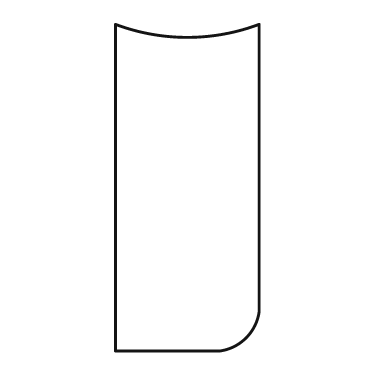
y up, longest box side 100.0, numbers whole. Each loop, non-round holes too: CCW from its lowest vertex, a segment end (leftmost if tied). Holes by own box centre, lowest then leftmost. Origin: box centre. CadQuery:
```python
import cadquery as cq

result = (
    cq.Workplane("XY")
    .moveTo(-22.0, -50.0)
    .lineTo(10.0, -50.0)
    .threePointArc((18.0, -46.0), (22.0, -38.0))
    .lineTo(22.0, 50.0)
    .threePointArc((0.0, 46.0), (-22.0, 50.0))
    .close()
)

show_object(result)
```